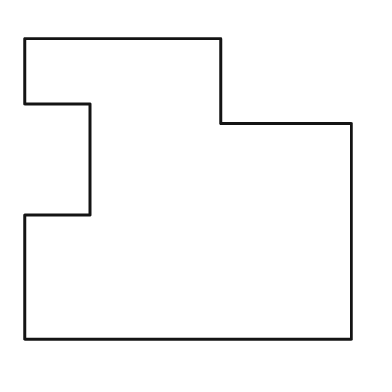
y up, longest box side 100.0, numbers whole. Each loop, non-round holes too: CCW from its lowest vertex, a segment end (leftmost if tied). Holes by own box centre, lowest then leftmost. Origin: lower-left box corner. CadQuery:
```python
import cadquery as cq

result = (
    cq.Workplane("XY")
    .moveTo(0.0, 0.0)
    .lineTo(100.0, 0.0)
    .lineTo(100.0, 66.0)
    .lineTo(60.0, 66.0)
    .lineTo(60.0, 92.0)
    .lineTo(0.0, 92.0)
    .lineTo(0.0, 72.0)
    .lineTo(20.0, 72.0)
    .lineTo(20.0, 38.0)
    .lineTo(0.0, 38.0)
    .close()
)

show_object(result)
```